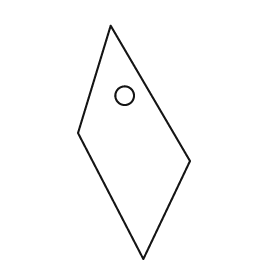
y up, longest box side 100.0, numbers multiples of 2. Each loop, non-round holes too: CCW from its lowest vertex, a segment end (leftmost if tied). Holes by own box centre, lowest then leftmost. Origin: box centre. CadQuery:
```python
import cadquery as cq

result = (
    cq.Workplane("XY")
    .moveTo(4.0, -50.0)
    .lineTo(24.0, -8.0)
    .lineTo(-10.0, 50.0)
    .lineTo(-24.0, 4.0)
    .close()
    .moveTo(-4.0, 20.0)
    .circle(4.0)
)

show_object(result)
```